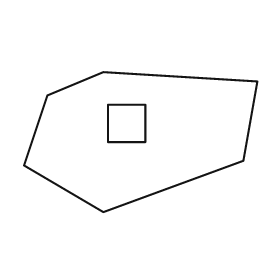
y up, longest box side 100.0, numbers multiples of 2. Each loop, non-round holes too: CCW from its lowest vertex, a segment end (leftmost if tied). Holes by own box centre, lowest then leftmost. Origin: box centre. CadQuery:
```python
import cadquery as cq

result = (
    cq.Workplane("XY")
    .moveTo(-16.0, -30.0)
    .lineTo(44.0, -8.0)
    .lineTo(50.0, 26.0)
    .lineTo(-16.0, 30.0)
    .lineTo(-40.0, 20.0)
    .lineTo(-50.0, -10.0)
    .close()
    .moveTo(-14.0, 0.0)
    .lineTo(2.0, 0.0)
    .lineTo(2.0, 16.0)
    .lineTo(-14.0, 16.0)
    .close()
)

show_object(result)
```